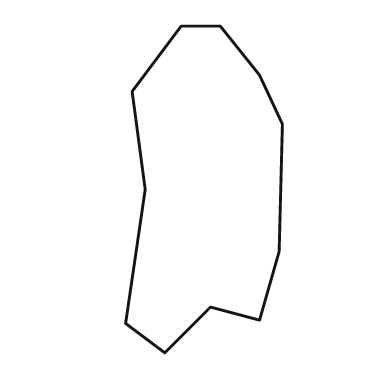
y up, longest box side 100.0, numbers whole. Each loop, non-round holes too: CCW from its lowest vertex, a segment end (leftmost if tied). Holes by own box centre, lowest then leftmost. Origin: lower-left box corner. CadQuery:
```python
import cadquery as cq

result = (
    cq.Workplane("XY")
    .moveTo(12.0, 0.0)
    .lineTo(26.0, 14.0)
    .lineTo(41.0, 10.0)
    .lineTo(47.0, 31.0)
    .lineTo(48.0, 70.0)
    .lineTo(41.0, 85.0)
    .lineTo(29.0, 100.0)
    .lineTo(17.0, 100.0)
    .lineTo(2.0, 80.0)
    .lineTo(6.0, 50.0)
    .lineTo(0.0, 9.0)
    .close()
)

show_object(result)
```